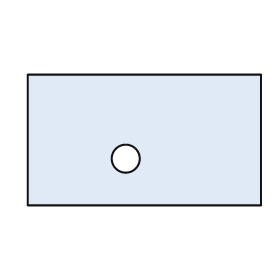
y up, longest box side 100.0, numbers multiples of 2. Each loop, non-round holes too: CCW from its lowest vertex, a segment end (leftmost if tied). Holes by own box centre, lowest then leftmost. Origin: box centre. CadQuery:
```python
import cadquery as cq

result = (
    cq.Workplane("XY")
    .moveTo(-50.0, -28.0)
    .lineTo(50.0, -28.0)
    .lineTo(50.0, 28.0)
    .lineTo(-50.0, 28.0)
    .close()
    .moveTo(-8.0, -8.0)
    .circle(6.0)
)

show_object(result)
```